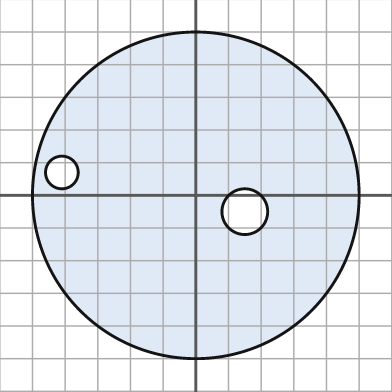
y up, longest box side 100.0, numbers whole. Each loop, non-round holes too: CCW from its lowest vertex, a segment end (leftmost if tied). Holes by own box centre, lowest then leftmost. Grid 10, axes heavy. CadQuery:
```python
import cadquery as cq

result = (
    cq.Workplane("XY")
    .moveTo(0.0, 0.0)
    .circle(50.0)
    .moveTo(15.0, -5.0)
    .circle(7.0)
    .moveTo(-41.0, 7.0)
    .circle(5.0)
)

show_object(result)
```